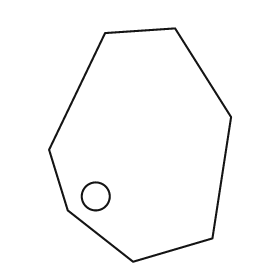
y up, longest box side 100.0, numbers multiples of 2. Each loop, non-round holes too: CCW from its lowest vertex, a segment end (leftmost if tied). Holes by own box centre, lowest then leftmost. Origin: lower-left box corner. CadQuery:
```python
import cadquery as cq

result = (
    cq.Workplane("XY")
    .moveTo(36.0, 0.0)
    .lineTo(70.0, 10.0)
    .lineTo(78.0, 62.0)
    .lineTo(54.0, 100.0)
    .lineTo(24.0, 98.0)
    .lineTo(0.0, 48.0)
    .lineTo(8.0, 22.0)
    .close()
    .moveTo(20.0, 28.0)
    .circle(6.0)
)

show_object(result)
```